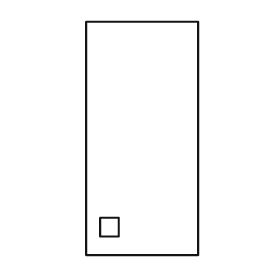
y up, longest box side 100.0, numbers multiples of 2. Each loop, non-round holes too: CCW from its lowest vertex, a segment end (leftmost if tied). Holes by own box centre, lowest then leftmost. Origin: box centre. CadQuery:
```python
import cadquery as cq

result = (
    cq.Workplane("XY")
    .moveTo(-24.0, -50.0)
    .lineTo(24.0, -50.0)
    .lineTo(24.0, 50.0)
    .lineTo(-24.0, 50.0)
    .close()
    .moveTo(-18.0, -42.0)
    .lineTo(-10.0, -42.0)
    .lineTo(-10.0, -34.0)
    .lineTo(-18.0, -34.0)
    .close()
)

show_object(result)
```